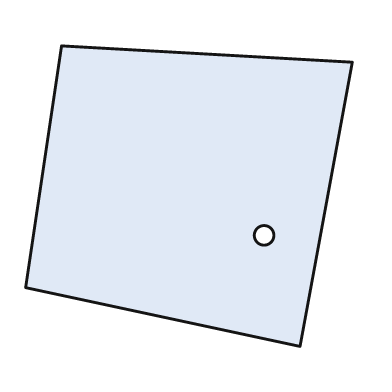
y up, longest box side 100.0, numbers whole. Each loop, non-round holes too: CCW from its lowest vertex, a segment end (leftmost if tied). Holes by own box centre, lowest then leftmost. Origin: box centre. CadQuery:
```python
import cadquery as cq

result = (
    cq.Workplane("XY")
    .moveTo(34.0, -46.0)
    .lineTo(50.0, 41.0)
    .lineTo(-39.0, 46.0)
    .lineTo(-50.0, -28.0)
    .close()
    .moveTo(23.0, -12.0)
    .circle(3.0)
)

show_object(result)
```